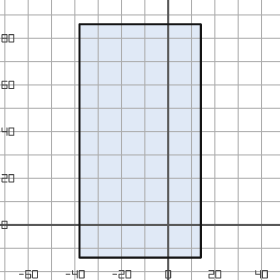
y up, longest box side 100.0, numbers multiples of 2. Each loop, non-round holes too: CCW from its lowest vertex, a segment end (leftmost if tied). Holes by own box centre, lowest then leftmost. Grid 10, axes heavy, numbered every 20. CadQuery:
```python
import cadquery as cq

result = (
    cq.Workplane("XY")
    .moveTo(-38.0, -14.0)
    .lineTo(14.0, -14.0)
    .lineTo(14.0, 86.0)
    .lineTo(-38.0, 86.0)
    .close()
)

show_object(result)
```